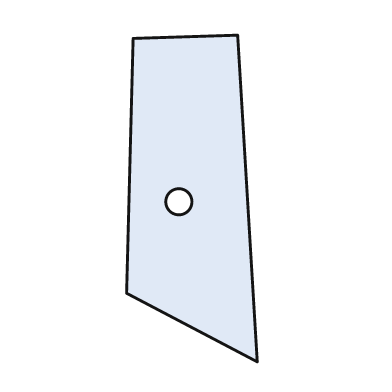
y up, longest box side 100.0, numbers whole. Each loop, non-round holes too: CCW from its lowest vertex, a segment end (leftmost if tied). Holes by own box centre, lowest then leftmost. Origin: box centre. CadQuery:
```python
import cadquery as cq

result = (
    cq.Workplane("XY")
    .moveTo(20.0, -50.0)
    .lineTo(14.0, 50.0)
    .lineTo(-18.0, 49.0)
    .lineTo(-20.0, -29.0)
    .close()
    .moveTo(-4.0, -1.0)
    .circle(4.0)
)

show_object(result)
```